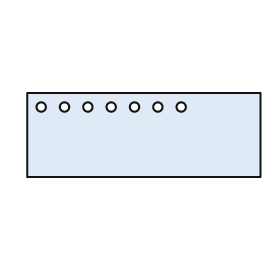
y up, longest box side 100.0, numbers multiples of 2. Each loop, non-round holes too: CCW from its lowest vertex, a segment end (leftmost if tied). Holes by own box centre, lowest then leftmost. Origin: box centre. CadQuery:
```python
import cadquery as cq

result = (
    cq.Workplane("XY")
    .moveTo(-50.0, -18.0)
    .lineTo(50.0, -18.0)
    .lineTo(50.0, 18.0)
    .lineTo(-50.0, 18.0)
    .close()
    .moveTo(-44.0, 12.0)
    .circle(2.0)
    .moveTo(-34.0, 12.0)
    .circle(2.0)
    .moveTo(-24.0, 12.0)
    .circle(2.0)
    .moveTo(-14.0, 12.0)
    .circle(2.0)
    .moveTo(-4.0, 12.0)
    .circle(2.0)
    .moveTo(6.0, 12.0)
    .circle(2.0)
    .moveTo(16.0, 12.0)
    .circle(2.0)
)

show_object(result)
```